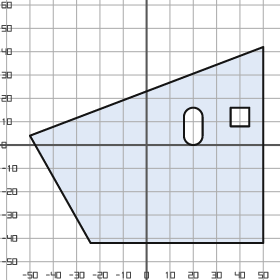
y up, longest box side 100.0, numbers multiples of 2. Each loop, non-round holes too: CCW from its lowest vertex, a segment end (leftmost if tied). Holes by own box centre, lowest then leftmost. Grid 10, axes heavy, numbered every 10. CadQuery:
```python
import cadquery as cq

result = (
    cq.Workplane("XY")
    .moveTo(-24.0, -42.0)
    .lineTo(50.0, -42.0)
    .lineTo(50.0, 42.0)
    .lineTo(-50.0, 4.0)
    .close()
    .moveTo(16.0, 4.0)
    .threePointArc((20.0, 0.0), (24.0, 4.0))
    .lineTo(24.0, 12.0)
    .threePointArc((20.0, 16.0), (16.0, 12.0))
    .close()
    .moveTo(36.0, 8.0)
    .lineTo(44.0, 8.0)
    .lineTo(44.0, 16.0)
    .lineTo(36.0, 16.0)
    .close()
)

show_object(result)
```